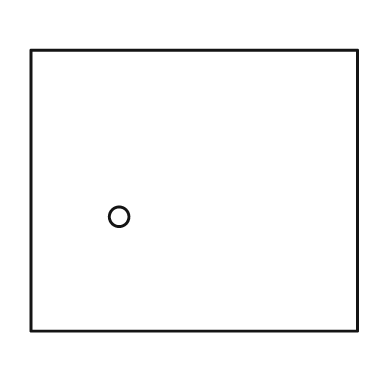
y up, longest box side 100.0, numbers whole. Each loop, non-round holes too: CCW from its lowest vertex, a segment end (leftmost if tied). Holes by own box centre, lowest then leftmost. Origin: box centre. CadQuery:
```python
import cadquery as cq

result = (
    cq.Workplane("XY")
    .moveTo(-50.0, -43.0)
    .lineTo(50.0, -43.0)
    .lineTo(50.0, 43.0)
    .lineTo(-50.0, 43.0)
    .close()
    .moveTo(-23.0, -8.0)
    .circle(3.0)
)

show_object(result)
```